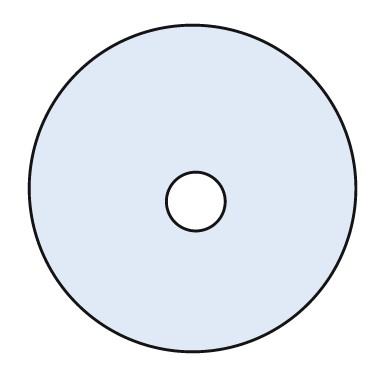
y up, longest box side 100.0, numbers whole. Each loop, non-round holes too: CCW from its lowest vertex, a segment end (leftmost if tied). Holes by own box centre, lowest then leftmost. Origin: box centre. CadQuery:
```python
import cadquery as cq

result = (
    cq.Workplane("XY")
    .moveTo(0.0, 0.0)
    .circle(50.0)
    .moveTo(1.0, -4.0)
    .circle(9.0)
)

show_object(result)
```